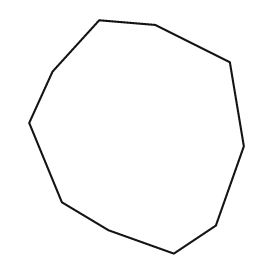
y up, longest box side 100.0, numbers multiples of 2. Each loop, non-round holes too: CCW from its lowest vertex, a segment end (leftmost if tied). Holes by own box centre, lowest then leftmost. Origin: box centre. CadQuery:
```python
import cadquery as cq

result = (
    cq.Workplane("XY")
    .moveTo(16.0, -50.0)
    .lineTo(34.0, -38.0)
    .lineTo(46.0, -4.0)
    .lineTo(40.0, 32.0)
    .lineTo(8.0, 48.0)
    .lineTo(-16.0, 50.0)
    .lineTo(-36.0, 28.0)
    .lineTo(-46.0, 6.0)
    .lineTo(-32.0, -28.0)
    .lineTo(-12.0, -40.0)
    .close()
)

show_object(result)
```